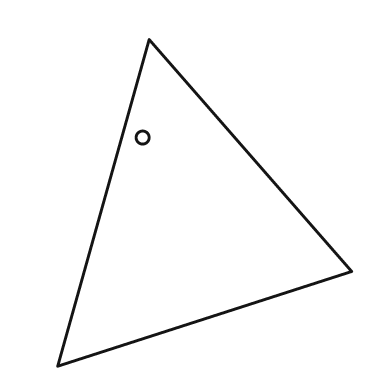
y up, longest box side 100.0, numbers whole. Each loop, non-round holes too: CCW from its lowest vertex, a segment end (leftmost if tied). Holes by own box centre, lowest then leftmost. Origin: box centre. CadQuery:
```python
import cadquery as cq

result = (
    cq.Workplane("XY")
    .moveTo(-45.0, -50.0)
    .lineTo(45.0, -21.0)
    .lineTo(-17.0, 50.0)
    .close()
    .moveTo(-19.0, 20.0)
    .circle(2.0)
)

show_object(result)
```